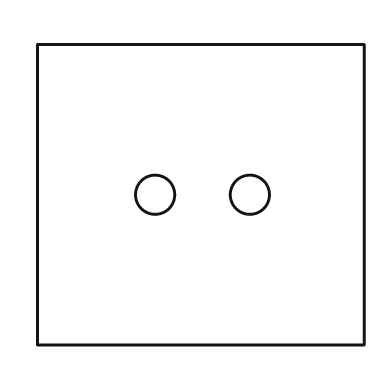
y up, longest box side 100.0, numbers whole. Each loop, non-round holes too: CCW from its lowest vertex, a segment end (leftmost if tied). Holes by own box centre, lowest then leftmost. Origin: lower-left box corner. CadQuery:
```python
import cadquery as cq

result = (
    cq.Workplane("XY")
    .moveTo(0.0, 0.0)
    .lineTo(100.0, 0.0)
    .lineTo(100.0, 92.0)
    .lineTo(0.0, 92.0)
    .close()
    .moveTo(36.0, 46.0)
    .circle(6.0)
    .moveTo(65.0, 46.0)
    .circle(6.0)
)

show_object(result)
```